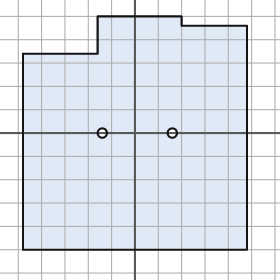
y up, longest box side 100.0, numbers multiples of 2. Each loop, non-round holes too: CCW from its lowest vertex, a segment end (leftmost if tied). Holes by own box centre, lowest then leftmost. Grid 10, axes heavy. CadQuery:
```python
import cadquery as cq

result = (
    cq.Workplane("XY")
    .moveTo(-48.0, -50.0)
    .lineTo(48.0, -50.0)
    .lineTo(48.0, 46.0)
    .lineTo(20.0, 46.0)
    .lineTo(20.0, 50.0)
    .lineTo(-16.0, 50.0)
    .lineTo(-16.0, 34.0)
    .lineTo(-48.0, 34.0)
    .close()
    .moveTo(-14.0, 0.0)
    .circle(2.0)
    .moveTo(16.0, 0.0)
    .circle(2.0)
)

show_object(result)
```